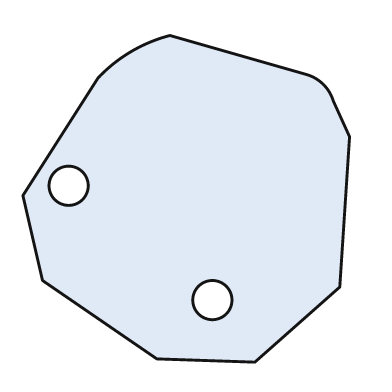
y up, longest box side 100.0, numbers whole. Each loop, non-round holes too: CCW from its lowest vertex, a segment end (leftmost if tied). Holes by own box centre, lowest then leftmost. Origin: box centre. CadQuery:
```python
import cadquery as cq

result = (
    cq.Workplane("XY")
    .moveTo(21.0, -50.0)
    .lineTo(47.0, -27.0)
    .lineTo(50.0, 19.0)
    .lineTo(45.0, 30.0)
    .threePointArc((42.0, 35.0), (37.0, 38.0))
    .lineTo(-5.0, 50.0)
    .threePointArc((-17.0, 45.0), (-27.0, 37.0))
    .lineTo(-50.0, 1.0)
    .lineTo(-44.0, -25.0)
    .lineTo(-9.0, -49.0)
    .close()
    .moveTo(8.0, -31.0)
    .circle(6.0)
    .moveTo(-36.0, 4.0)
    .circle(6.0)
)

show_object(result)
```